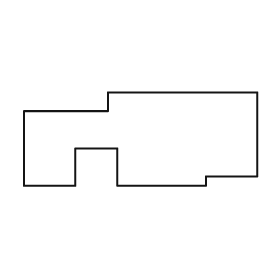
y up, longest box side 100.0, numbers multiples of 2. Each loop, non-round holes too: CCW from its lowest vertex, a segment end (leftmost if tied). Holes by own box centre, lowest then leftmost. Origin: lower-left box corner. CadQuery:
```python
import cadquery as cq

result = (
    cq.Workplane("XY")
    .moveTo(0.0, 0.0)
    .lineTo(22.0, 0.0)
    .lineTo(22.0, 16.0)
    .lineTo(40.0, 16.0)
    .lineTo(40.0, 0.0)
    .lineTo(78.0, 0.0)
    .lineTo(78.0, 4.0)
    .lineTo(100.0, 4.0)
    .lineTo(100.0, 40.0)
    .lineTo(36.0, 40.0)
    .lineTo(36.0, 32.0)
    .lineTo(0.0, 32.0)
    .close()
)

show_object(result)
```